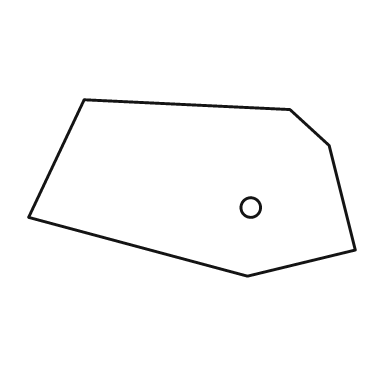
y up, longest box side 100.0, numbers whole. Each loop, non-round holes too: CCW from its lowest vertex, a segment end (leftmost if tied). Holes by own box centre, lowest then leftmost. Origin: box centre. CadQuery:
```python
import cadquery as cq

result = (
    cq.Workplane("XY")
    .moveTo(17.0, -27.0)
    .lineTo(50.0, -19.0)
    .lineTo(42.0, 13.0)
    .lineTo(30.0, 24.0)
    .lineTo(-33.0, 27.0)
    .lineTo(-50.0, -9.0)
    .close()
    .moveTo(18.0, -6.0)
    .circle(3.0)
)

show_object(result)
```